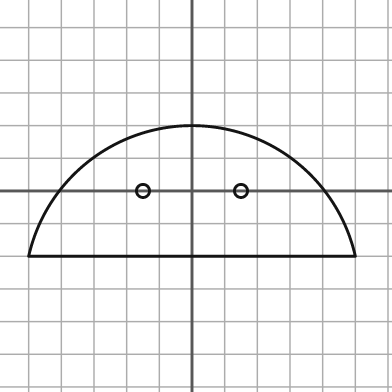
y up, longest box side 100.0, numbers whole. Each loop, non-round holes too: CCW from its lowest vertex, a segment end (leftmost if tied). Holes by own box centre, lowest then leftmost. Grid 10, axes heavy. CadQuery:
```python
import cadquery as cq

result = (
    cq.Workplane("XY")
    .moveTo(-50.0, -20.0)
    .lineTo(50.0, -20.0)
    .threePointArc((0.0, 20.0), (-50.0, -20.0))
    .close()
    .moveTo(-15.0, 0.0)
    .circle(2.0)
    .moveTo(15.0, 0.0)
    .circle(2.0)
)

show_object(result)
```